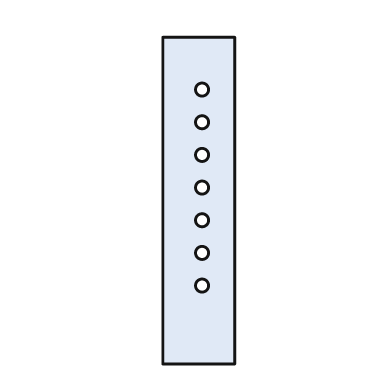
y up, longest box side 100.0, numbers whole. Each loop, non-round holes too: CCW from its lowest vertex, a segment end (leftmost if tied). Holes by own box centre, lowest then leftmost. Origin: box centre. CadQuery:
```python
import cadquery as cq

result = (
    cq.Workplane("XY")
    .moveTo(-11.0, -50.0)
    .lineTo(11.0, -50.0)
    .lineTo(11.0, 50.0)
    .lineTo(-11.0, 50.0)
    .close()
    .moveTo(1.0, -26.0)
    .circle(2.0)
    .moveTo(1.0, -16.0)
    .circle(2.0)
    .moveTo(1.0, -6.0)
    .circle(2.0)
    .moveTo(1.0, 4.0)
    .circle(2.0)
    .moveTo(1.0, 14.0)
    .circle(2.0)
    .moveTo(1.0, 24.0)
    .circle(2.0)
    .moveTo(1.0, 34.0)
    .circle(2.0)
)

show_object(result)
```